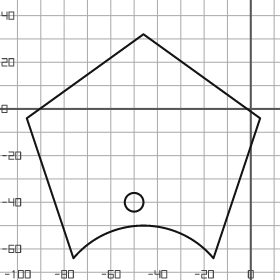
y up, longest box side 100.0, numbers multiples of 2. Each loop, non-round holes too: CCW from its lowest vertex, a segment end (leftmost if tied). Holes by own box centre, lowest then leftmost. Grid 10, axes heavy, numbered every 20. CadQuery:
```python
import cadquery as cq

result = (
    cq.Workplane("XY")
    .moveTo(-76.0, -64.0)
    .threePointArc((-46.0, -50.0), (-16.0, -64.0))
    .lineTo(4.0, -4.0)
    .lineTo(-46.0, 32.0)
    .lineTo(-96.0, -4.0)
    .close()
    .moveTo(-50.0, -40.0)
    .circle(4.0)
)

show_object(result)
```